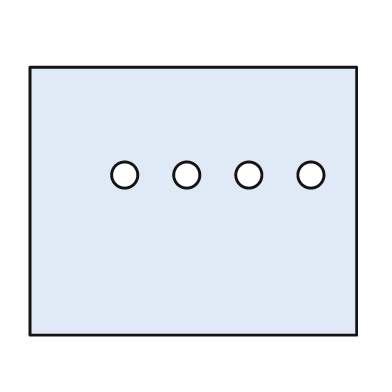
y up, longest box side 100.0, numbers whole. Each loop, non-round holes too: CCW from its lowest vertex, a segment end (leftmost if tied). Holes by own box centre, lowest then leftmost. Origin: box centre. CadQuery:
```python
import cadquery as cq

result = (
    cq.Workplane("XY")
    .moveTo(-50.0, -41.0)
    .lineTo(50.0, -41.0)
    .lineTo(50.0, 41.0)
    .lineTo(-50.0, 41.0)
    .close()
    .moveTo(-21.0, 8.0)
    .circle(4.0)
    .moveTo(-2.0, 8.0)
    .circle(4.0)
    .moveTo(17.0, 8.0)
    .circle(4.0)
    .moveTo(36.0, 8.0)
    .circle(4.0)
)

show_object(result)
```